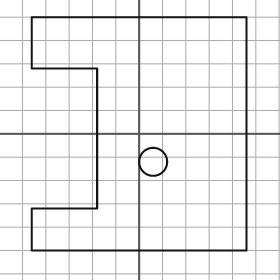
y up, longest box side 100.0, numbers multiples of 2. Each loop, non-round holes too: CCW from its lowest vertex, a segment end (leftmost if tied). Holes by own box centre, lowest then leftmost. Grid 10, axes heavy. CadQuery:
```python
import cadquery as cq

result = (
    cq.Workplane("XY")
    .moveTo(-46.0, -50.0)
    .lineTo(46.0, -50.0)
    .lineTo(46.0, 50.0)
    .lineTo(-46.0, 50.0)
    .lineTo(-46.0, 28.0)
    .lineTo(-18.0, 28.0)
    .lineTo(-18.0, -32.0)
    .lineTo(-46.0, -32.0)
    .close()
    .moveTo(6.0, -12.0)
    .circle(6.0)
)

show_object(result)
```